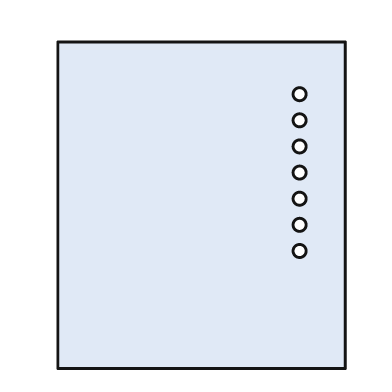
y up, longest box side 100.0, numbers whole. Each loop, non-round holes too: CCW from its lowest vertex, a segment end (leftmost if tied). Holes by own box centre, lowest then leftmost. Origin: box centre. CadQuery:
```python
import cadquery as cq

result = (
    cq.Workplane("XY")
    .moveTo(-44.0, -50.0)
    .lineTo(44.0, -50.0)
    .lineTo(44.0, 50.0)
    .lineTo(-44.0, 50.0)
    .close()
    .moveTo(30.0, -14.0)
    .circle(2.0)
    .moveTo(30.0, -6.0)
    .circle(2.0)
    .moveTo(30.0, 2.0)
    .circle(2.0)
    .moveTo(30.0, 10.0)
    .circle(2.0)
    .moveTo(30.0, 18.0)
    .circle(2.0)
    .moveTo(30.0, 26.0)
    .circle(2.0)
    .moveTo(30.0, 34.0)
    .circle(2.0)
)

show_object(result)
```